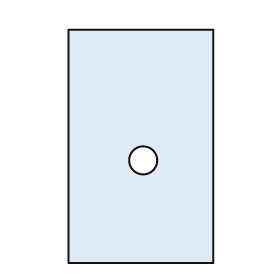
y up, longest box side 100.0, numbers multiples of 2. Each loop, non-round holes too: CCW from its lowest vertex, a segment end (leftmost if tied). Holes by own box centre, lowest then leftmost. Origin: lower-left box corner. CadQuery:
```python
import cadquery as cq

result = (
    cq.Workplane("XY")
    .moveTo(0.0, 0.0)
    .lineTo(62.0, 0.0)
    .lineTo(62.0, 100.0)
    .lineTo(0.0, 100.0)
    .close()
    .moveTo(32.0, 44.0)
    .circle(6.0)
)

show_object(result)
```